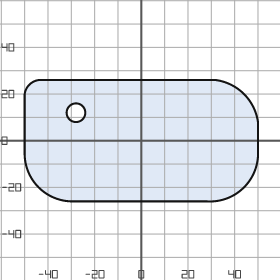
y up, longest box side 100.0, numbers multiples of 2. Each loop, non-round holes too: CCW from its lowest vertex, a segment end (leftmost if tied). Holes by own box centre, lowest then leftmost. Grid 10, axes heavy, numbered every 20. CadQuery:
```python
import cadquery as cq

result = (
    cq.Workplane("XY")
    .moveTo(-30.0, -26.0)
    .lineTo(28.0, -26.0)
    .threePointArc((44.0, -20.0), (50.0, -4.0))
    .lineTo(50.0, 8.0)
    .threePointArc((44.0, 20.0), (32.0, 26.0))
    .lineTo(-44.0, 26.0)
    .threePointArc((-48.0, 24.0), (-50.0, 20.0))
    .lineTo(-50.0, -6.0)
    .threePointArc((-44.0, -20.0), (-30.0, -26.0))
    .close()
    .moveTo(-28.0, 12.0)
    .circle(4.0)
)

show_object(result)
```